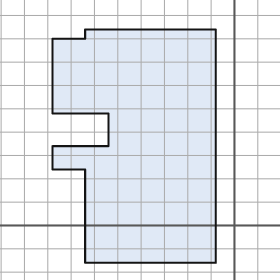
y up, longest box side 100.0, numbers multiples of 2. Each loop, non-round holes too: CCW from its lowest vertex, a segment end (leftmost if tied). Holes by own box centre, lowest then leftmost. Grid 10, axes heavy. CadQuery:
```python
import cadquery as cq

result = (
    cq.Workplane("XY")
    .moveTo(-64.0, -16.0)
    .lineTo(-8.0, -16.0)
    .lineTo(-8.0, 84.0)
    .lineTo(-64.0, 84.0)
    .lineTo(-64.0, 80.0)
    .lineTo(-78.0, 80.0)
    .lineTo(-78.0, 48.0)
    .lineTo(-54.0, 48.0)
    .lineTo(-54.0, 34.0)
    .lineTo(-78.0, 34.0)
    .lineTo(-78.0, 24.0)
    .lineTo(-64.0, 24.0)
    .close()
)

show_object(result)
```